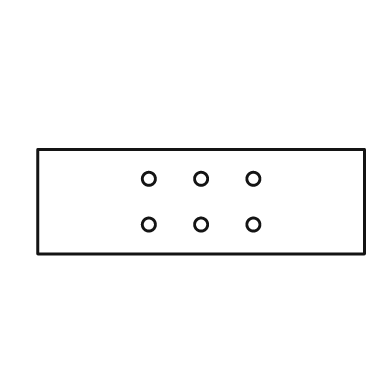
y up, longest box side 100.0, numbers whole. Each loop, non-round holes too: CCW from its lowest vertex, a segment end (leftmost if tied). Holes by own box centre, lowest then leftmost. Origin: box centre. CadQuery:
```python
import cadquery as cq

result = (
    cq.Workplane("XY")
    .moveTo(-50.0, -16.0)
    .lineTo(50.0, -16.0)
    .lineTo(50.0, 16.0)
    .lineTo(-50.0, 16.0)
    .close()
    .moveTo(-16.0, -7.0)
    .circle(2.0)
    .moveTo(0.0, -7.0)
    .circle(2.0)
    .moveTo(16.0, -7.0)
    .circle(2.0)
    .moveTo(-16.0, 7.0)
    .circle(2.0)
    .moveTo(0.0, 7.0)
    .circle(2.0)
    .moveTo(16.0, 7.0)
    .circle(2.0)
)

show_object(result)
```